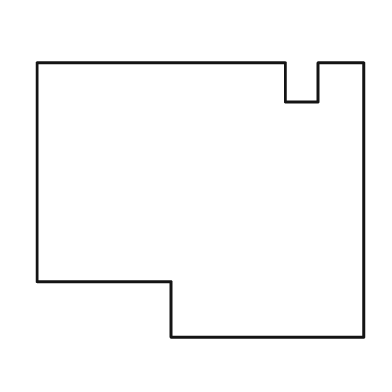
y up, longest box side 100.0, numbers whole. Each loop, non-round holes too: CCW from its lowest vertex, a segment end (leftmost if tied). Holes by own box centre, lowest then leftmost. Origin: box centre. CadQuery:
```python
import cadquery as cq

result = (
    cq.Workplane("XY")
    .moveTo(-9.0, -42.0)
    .lineTo(50.0, -42.0)
    .lineTo(50.0, 42.0)
    .lineTo(36.0, 42.0)
    .lineTo(36.0, 30.0)
    .lineTo(26.0, 30.0)
    .lineTo(26.0, 42.0)
    .lineTo(-50.0, 42.0)
    .lineTo(-50.0, -25.0)
    .lineTo(-9.0, -25.0)
    .close()
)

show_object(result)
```